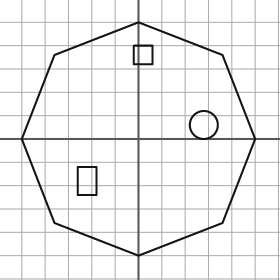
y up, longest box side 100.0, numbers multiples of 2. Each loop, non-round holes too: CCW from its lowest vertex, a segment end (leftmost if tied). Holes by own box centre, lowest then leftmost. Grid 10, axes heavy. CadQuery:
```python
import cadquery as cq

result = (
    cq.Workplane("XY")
    .moveTo(0.0, -50.0)
    .lineTo(36.0, -36.0)
    .lineTo(50.0, 0.0)
    .lineTo(36.0, 36.0)
    .lineTo(0.0, 50.0)
    .lineTo(-36.0, 36.0)
    .lineTo(-50.0, 0.0)
    .lineTo(-36.0, -36.0)
    .close()
    .moveTo(-26.0, -24.0)
    .lineTo(-18.0, -24.0)
    .lineTo(-18.0, -12.0)
    .lineTo(-26.0, -12.0)
    .close()
    .moveTo(28.0, 6.0)
    .circle(6.0)
    .moveTo(-2.0, 32.0)
    .lineTo(6.0, 32.0)
    .lineTo(6.0, 40.0)
    .lineTo(-2.0, 40.0)
    .close()
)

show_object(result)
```